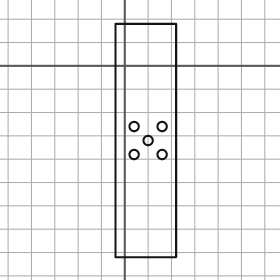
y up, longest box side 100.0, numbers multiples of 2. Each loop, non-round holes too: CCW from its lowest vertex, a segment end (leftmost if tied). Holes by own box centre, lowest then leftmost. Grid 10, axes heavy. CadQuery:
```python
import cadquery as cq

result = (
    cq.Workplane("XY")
    .moveTo(-4.0, -82.0)
    .lineTo(22.0, -82.0)
    .lineTo(22.0, 18.0)
    .lineTo(-4.0, 18.0)
    .close()
    .moveTo(4.0, -38.0)
    .circle(2.0)
    .moveTo(16.0, -38.0)
    .circle(2.0)
    .moveTo(10.0, -32.0)
    .circle(2.0)
    .moveTo(4.0, -26.0)
    .circle(2.0)
    .moveTo(16.0, -26.0)
    .circle(2.0)
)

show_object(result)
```